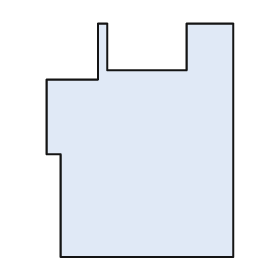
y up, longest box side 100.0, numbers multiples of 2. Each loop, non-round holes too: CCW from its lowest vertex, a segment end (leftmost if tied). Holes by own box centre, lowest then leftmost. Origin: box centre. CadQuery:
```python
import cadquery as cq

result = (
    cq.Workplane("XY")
    .moveTo(-34.0, -50.0)
    .lineTo(40.0, -50.0)
    .lineTo(40.0, 50.0)
    .lineTo(20.0, 50.0)
    .lineTo(20.0, 30.0)
    .lineTo(-14.0, 30.0)
    .lineTo(-14.0, 50.0)
    .lineTo(-18.0, 50.0)
    .lineTo(-18.0, 26.0)
    .lineTo(-40.0, 26.0)
    .lineTo(-40.0, -6.0)
    .lineTo(-34.0, -6.0)
    .close()
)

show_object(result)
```